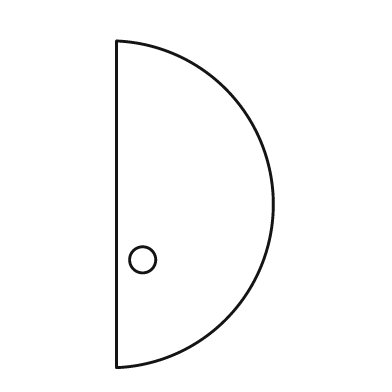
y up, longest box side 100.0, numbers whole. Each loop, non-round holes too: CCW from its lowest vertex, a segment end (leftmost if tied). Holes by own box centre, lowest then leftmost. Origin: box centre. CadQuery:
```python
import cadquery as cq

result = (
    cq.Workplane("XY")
    .moveTo(-24.0, -50.0)
    .threePointArc((24.0, 0.0), (-24.0, 50.0))
    .close()
    .moveTo(-16.0, -17.0)
    .circle(4.0)
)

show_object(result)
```